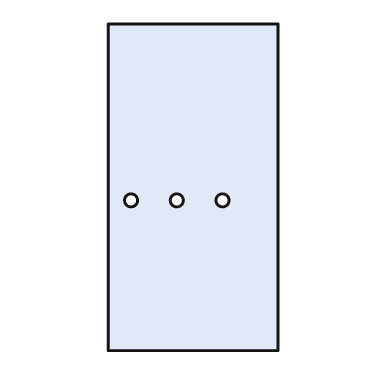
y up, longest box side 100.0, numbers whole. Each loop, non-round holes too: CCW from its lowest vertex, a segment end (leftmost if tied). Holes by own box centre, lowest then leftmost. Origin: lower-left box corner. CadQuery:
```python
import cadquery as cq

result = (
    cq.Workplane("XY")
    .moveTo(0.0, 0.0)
    .lineTo(52.0, 0.0)
    .lineTo(52.0, 100.0)
    .lineTo(0.0, 100.0)
    .close()
    .moveTo(7.0, 46.0)
    .circle(2.0)
    .moveTo(21.0, 46.0)
    .circle(2.0)
    .moveTo(35.0, 46.0)
    .circle(2.0)
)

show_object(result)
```